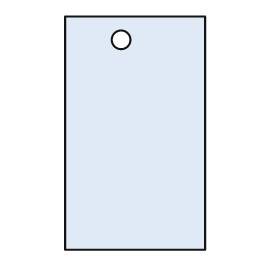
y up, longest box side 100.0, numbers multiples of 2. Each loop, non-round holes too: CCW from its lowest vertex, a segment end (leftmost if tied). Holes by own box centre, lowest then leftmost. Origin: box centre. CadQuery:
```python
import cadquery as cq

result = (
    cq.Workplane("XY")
    .moveTo(-30.0, -50.0)
    .lineTo(30.0, -50.0)
    .lineTo(30.0, 50.0)
    .lineTo(-30.0, 50.0)
    .close()
    .moveTo(-6.0, 40.0)
    .circle(4.0)
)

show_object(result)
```